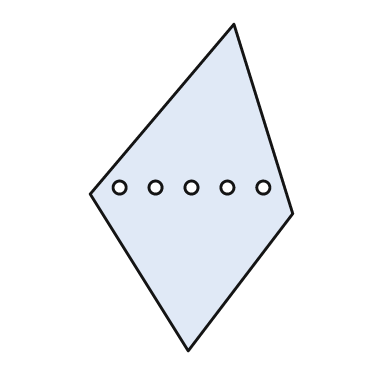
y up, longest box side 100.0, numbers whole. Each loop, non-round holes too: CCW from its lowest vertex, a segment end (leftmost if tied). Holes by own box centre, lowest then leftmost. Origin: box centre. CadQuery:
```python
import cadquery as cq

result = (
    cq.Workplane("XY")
    .moveTo(-1.0, -50.0)
    .lineTo(31.0, -8.0)
    .lineTo(13.0, 50.0)
    .lineTo(-31.0, -2.0)
    .close()
    .moveTo(-22.0, 0.0)
    .circle(2.0)
    .moveTo(-11.0, 0.0)
    .circle(2.0)
    .moveTo(0.0, 0.0)
    .circle(2.0)
    .moveTo(11.0, 0.0)
    .circle(2.0)
    .moveTo(22.0, 0.0)
    .circle(2.0)
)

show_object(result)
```